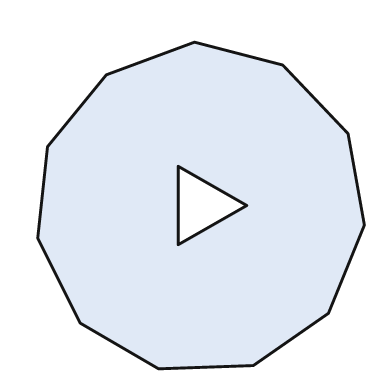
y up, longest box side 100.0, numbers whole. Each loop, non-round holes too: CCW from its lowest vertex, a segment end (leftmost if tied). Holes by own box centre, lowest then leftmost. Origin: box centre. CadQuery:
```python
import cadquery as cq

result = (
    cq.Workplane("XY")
    .moveTo(-13.0, -50.0)
    .lineTo(16.0, -49.0)
    .lineTo(39.0, -33.0)
    .lineTo(50.0, -6.0)
    .lineTo(45.0, 22.0)
    .lineTo(25.0, 43.0)
    .lineTo(-2.0, 50.0)
    .lineTo(-29.0, 40.0)
    .lineTo(-47.0, 18.0)
    .lineTo(-50.0, -10.0)
    .lineTo(-37.0, -36.0)
    .close()
    .moveTo(-7.0, -12.0)
    .lineTo(14.0, 0.0)
    .lineTo(-7.0, 12.0)
    .close()
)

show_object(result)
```